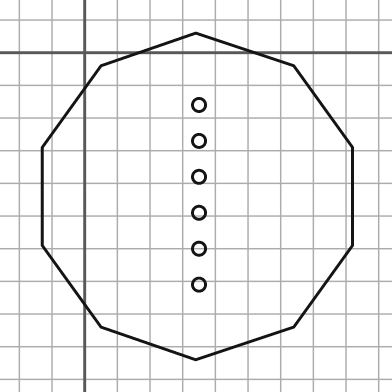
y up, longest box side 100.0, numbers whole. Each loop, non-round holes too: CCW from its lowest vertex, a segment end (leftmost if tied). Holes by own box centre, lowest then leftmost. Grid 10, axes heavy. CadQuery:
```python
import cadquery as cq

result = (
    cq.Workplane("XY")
    .moveTo(34.0, -94.0)
    .lineTo(64.0, -84.0)
    .lineTo(82.0, -59.0)
    .lineTo(82.0, -29.0)
    .lineTo(64.0, -4.0)
    .lineTo(34.0, 6.0)
    .lineTo(5.0, -4.0)
    .lineTo(-13.0, -29.0)
    .lineTo(-13.0, -59.0)
    .lineTo(5.0, -84.0)
    .close()
    .moveTo(35.0, -71.0)
    .circle(2.0)
    .moveTo(35.0, -60.0)
    .circle(2.0)
    .moveTo(35.0, -49.0)
    .circle(2.0)
    .moveTo(35.0, -38.0)
    .circle(2.0)
    .moveTo(35.0, -27.0)
    .circle(2.0)
    .moveTo(35.0, -16.0)
    .circle(2.0)
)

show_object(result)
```